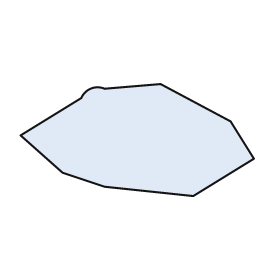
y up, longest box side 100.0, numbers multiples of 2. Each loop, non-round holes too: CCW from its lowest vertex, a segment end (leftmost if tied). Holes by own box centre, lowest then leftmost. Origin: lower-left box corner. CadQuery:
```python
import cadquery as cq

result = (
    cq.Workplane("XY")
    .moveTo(74.0, 0.0)
    .lineTo(100.0, 16.0)
    .lineTo(90.0, 32.0)
    .lineTo(60.0, 48.0)
    .lineTo(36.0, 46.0)
    .threePointArc((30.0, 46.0), (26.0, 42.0))
    .lineTo(0.0, 26.0)
    .lineTo(18.0, 10.0)
    .lineTo(36.0, 4.0)
    .close()
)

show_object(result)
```